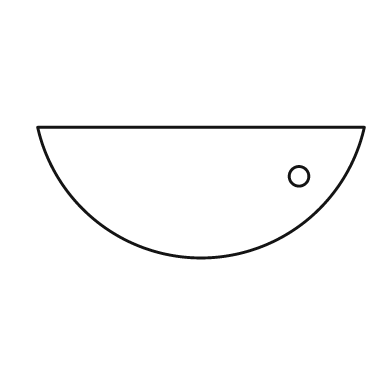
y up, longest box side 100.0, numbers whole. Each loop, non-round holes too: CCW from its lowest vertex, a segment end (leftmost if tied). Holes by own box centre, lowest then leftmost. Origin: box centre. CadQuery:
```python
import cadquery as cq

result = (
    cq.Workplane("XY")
    .moveTo(-50.0, 20.0)
    .threePointArc((0.0, -20.0), (50.0, 20.0))
    .close()
    .moveTo(30.0, 5.0)
    .circle(3.0)
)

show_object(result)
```